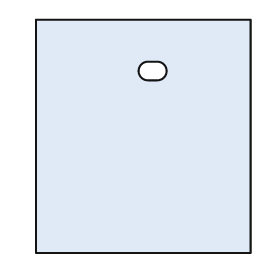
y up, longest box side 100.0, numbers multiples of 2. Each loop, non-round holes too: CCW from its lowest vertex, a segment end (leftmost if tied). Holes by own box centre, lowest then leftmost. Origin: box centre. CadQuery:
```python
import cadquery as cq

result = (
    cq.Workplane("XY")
    .moveTo(-46.0, -50.0)
    .lineTo(46.0, -50.0)
    .lineTo(46.0, 50.0)
    .lineTo(-46.0, 50.0)
    .close()
    .moveTo(2.0, 24.0)
    .lineTo(6.0, 24.0)
    .threePointArc((10.0, 28.0), (6.0, 32.0))
    .lineTo(2.0, 32.0)
    .threePointArc((-2.0, 28.0), (2.0, 24.0))
    .close()
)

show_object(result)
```